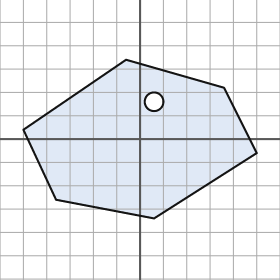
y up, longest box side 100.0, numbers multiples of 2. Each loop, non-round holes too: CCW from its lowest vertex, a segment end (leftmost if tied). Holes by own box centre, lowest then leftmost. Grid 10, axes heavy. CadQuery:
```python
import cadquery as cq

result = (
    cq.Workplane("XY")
    .moveTo(6.0, -34.0)
    .lineTo(50.0, -6.0)
    .lineTo(36.0, 22.0)
    .lineTo(-6.0, 34.0)
    .lineTo(-50.0, 4.0)
    .lineTo(-36.0, -26.0)
    .close()
    .moveTo(6.0, 16.0)
    .circle(4.0)
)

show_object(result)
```